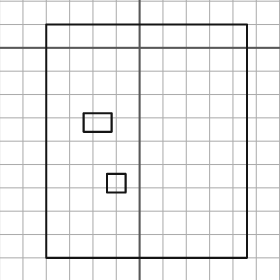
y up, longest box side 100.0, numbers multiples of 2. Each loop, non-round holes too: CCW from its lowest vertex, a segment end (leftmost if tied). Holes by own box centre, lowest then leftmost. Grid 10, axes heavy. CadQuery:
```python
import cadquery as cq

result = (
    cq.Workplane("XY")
    .moveTo(-40.0, -90.0)
    .lineTo(46.0, -90.0)
    .lineTo(46.0, 10.0)
    .lineTo(-40.0, 10.0)
    .close()
    .moveTo(-14.0, -62.0)
    .lineTo(-6.0, -62.0)
    .lineTo(-6.0, -54.0)
    .lineTo(-14.0, -54.0)
    .close()
    .moveTo(-24.0, -36.0)
    .lineTo(-12.0, -36.0)
    .lineTo(-12.0, -28.0)
    .lineTo(-24.0, -28.0)
    .close()
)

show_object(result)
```